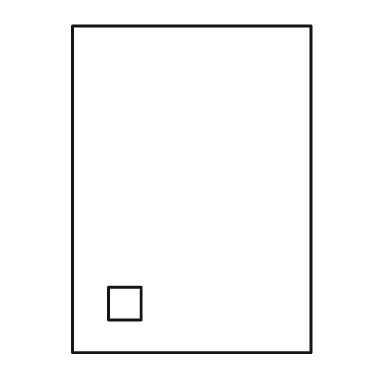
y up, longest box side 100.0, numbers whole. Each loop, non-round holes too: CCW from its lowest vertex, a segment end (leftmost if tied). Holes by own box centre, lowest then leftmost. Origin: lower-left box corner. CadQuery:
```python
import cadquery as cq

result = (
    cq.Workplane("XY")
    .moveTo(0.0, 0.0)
    .lineTo(73.0, 0.0)
    .lineTo(73.0, 100.0)
    .lineTo(0.0, 100.0)
    .close()
    .moveTo(11.0, 10.0)
    .lineTo(21.0, 10.0)
    .lineTo(21.0, 20.0)
    .lineTo(11.0, 20.0)
    .close()
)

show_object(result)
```